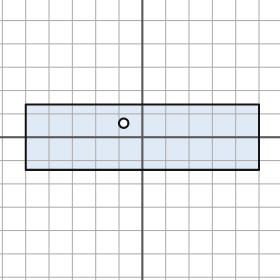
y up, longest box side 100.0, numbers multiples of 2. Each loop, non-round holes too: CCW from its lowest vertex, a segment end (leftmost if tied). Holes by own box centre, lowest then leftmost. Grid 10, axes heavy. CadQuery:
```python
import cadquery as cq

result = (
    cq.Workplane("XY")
    .moveTo(-50.0, -14.0)
    .lineTo(50.0, -14.0)
    .lineTo(50.0, 14.0)
    .lineTo(-50.0, 14.0)
    .close()
    .moveTo(-8.0, 6.0)
    .circle(2.0)
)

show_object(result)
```